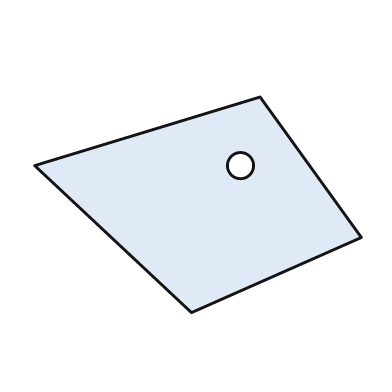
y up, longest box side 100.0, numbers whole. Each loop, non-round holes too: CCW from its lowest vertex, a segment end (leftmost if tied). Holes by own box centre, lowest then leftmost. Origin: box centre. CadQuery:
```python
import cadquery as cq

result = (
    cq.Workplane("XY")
    .moveTo(-2.0, -33.0)
    .lineTo(50.0, -10.0)
    .lineTo(19.0, 33.0)
    .lineTo(-50.0, 12.0)
    .close()
    .moveTo(13.0, 12.0)
    .circle(4.0)
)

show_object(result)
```